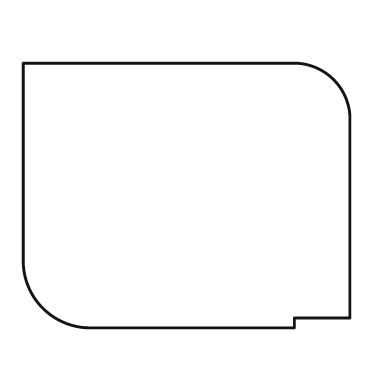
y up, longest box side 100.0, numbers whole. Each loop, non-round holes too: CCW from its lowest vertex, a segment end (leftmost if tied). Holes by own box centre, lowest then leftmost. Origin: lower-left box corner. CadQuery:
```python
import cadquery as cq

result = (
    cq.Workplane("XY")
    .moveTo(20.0, 0.0)
    .lineTo(83.0, 0.0)
    .lineTo(83.0, 3.0)
    .lineTo(100.0, 3.0)
    .lineTo(100.0, 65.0)
    .threePointArc((95.0, 76.0), (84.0, 81.0))
    .lineTo(0.0, 81.0)
    .lineTo(0.0, 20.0)
    .threePointArc((6.0, 6.0), (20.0, 0.0))
    .close()
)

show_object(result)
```